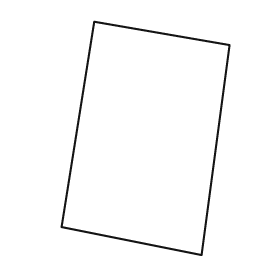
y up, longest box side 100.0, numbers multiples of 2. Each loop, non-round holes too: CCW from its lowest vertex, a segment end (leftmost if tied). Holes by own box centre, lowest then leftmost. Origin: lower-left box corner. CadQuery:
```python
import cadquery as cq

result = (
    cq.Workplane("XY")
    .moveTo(60.0, 0.0)
    .lineTo(72.0, 90.0)
    .lineTo(14.0, 100.0)
    .lineTo(0.0, 12.0)
    .close()
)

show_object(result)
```